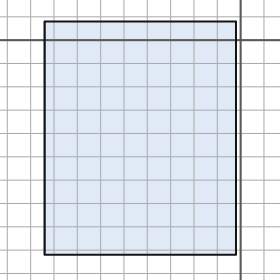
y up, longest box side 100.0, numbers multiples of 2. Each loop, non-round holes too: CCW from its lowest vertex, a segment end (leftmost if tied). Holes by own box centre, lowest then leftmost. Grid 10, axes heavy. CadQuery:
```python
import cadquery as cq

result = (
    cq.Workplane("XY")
    .moveTo(-84.0, -92.0)
    .lineTo(-2.0, -92.0)
    .lineTo(-2.0, 8.0)
    .lineTo(-84.0, 8.0)
    .close()
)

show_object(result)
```